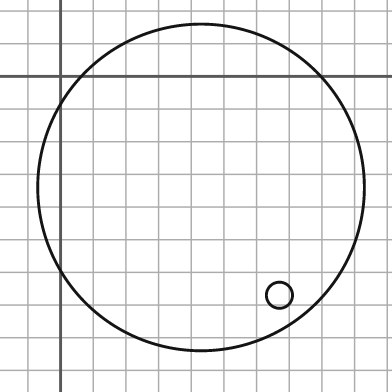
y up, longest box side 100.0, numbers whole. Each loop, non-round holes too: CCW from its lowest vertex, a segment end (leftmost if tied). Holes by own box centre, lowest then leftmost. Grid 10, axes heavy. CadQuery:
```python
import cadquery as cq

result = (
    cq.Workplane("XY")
    .moveTo(43.0, -34.0)
    .circle(50.0)
    .moveTo(67.0, -67.0)
    .circle(4.0)
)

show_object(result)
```